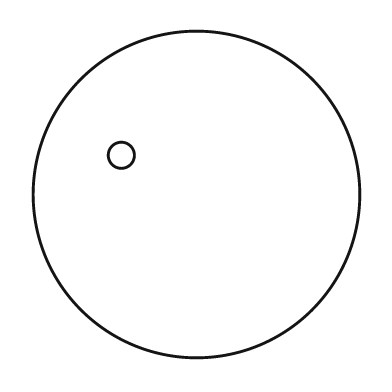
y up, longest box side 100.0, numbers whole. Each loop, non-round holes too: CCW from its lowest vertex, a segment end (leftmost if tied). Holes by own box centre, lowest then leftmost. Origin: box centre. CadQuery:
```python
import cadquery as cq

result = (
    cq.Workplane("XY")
    .moveTo(0.0, 0.0)
    .circle(50.0)
    .moveTo(-23.0, 12.0)
    .circle(4.0)
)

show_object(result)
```